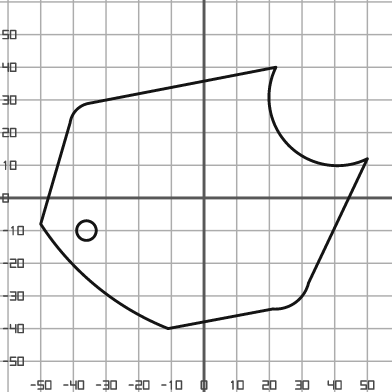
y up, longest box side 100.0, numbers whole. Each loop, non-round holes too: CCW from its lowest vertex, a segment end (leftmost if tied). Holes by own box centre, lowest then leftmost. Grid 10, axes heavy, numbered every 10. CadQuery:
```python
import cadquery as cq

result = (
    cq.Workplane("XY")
    .moveTo(-11.0, -40.0)
    .lineTo(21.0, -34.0)
    .threePointArc((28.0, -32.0), (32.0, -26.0))
    .lineTo(50.0, 12.0)
    .threePointArc((26.0, 16.0), (22.0, 40.0))
    .lineTo(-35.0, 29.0)
    .threePointArc((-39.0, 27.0), (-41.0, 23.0))
    .lineTo(-50.0, -8.0)
    .threePointArc((-33.0, -27.0), (-11.0, -40.0))
    .close()
    .moveTo(-36.0, -10.0)
    .circle(3.0)
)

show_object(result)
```